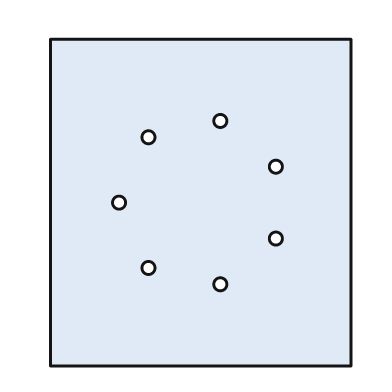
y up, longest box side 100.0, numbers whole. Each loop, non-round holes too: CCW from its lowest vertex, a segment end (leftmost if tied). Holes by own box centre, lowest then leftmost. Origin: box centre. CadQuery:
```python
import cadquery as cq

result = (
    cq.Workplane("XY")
    .moveTo(-46.0, -50.0)
    .lineTo(46.0, -50.0)
    .lineTo(46.0, 50.0)
    .lineTo(-46.0, 50.0)
    .close()
    .moveTo(6.0, -25.0)
    .circle(2.0)
    .moveTo(-16.0, -20.0)
    .circle(2.0)
    .moveTo(23.0, -11.0)
    .circle(2.0)
    .moveTo(-25.0, 0.0)
    .circle(2.0)
    .moveTo(23.0, 11.0)
    .circle(2.0)
    .moveTo(-16.0, 20.0)
    .circle(2.0)
    .moveTo(6.0, 25.0)
    .circle(2.0)
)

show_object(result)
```